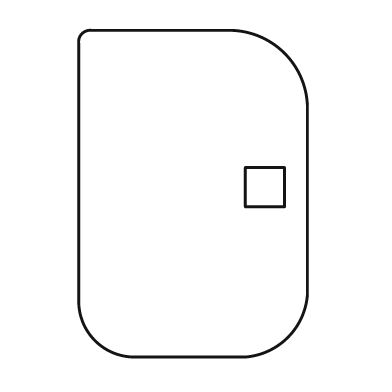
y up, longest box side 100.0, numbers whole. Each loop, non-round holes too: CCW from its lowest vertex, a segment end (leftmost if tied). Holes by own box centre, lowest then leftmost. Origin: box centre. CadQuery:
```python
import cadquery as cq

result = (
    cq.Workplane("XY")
    .moveTo(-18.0, -50.0)
    .lineTo(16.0, -50.0)
    .threePointArc((29.0, -44.0), (35.0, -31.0))
    .lineTo(35.0, 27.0)
    .threePointArc((28.0, 43.0), (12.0, 50.0))
    .lineTo(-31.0, 50.0)
    .threePointArc((-34.0, 49.0), (-35.0, 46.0))
    .lineTo(-35.0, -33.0)
    .threePointArc((-30.0, -45.0), (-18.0, -50.0))
    .close()
    .moveTo(16.0, -4.0)
    .lineTo(28.0, -4.0)
    .lineTo(28.0, 8.0)
    .lineTo(16.0, 8.0)
    .close()
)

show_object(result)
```